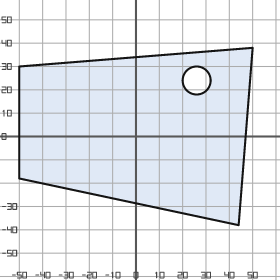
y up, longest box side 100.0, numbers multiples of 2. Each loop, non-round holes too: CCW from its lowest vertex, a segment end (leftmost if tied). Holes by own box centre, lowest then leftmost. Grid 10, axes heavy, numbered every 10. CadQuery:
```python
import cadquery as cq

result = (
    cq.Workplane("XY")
    .moveTo(44.0, -38.0)
    .lineTo(50.0, 38.0)
    .lineTo(-50.0, 30.0)
    .lineTo(-50.0, -18.0)
    .close()
    .moveTo(26.0, 24.0)
    .circle(6.0)
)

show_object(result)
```